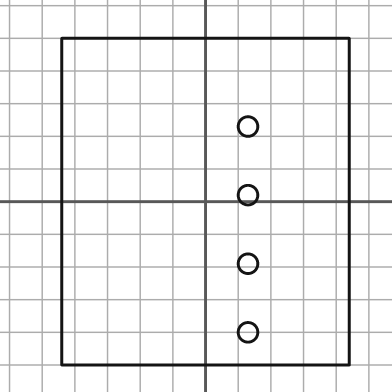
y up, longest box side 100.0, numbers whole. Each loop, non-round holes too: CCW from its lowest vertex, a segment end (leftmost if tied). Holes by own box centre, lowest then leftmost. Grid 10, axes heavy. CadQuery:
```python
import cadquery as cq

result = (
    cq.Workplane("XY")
    .moveTo(-44.0, -50.0)
    .lineTo(44.0, -50.0)
    .lineTo(44.0, 50.0)
    .lineTo(-44.0, 50.0)
    .close()
    .moveTo(13.0, -40.0)
    .circle(3.0)
    .moveTo(13.0, -19.0)
    .circle(3.0)
    .moveTo(13.0, 2.0)
    .circle(3.0)
    .moveTo(13.0, 23.0)
    .circle(3.0)
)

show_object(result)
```